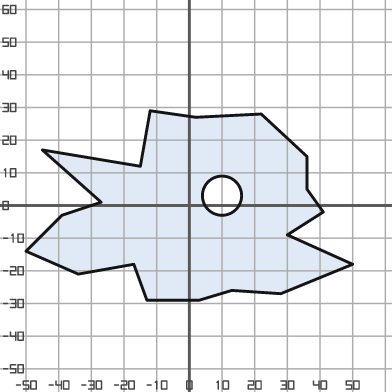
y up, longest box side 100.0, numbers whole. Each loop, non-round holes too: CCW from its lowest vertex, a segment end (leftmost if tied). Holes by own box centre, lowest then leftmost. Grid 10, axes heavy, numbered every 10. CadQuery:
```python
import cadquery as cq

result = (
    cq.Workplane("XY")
    .moveTo(-13.0, -29.0)
    .lineTo(3.0, -29.0)
    .lineTo(13.0, -26.0)
    .lineTo(28.0, -27.0)
    .lineTo(50.0, -18.0)
    .lineTo(30.0, -9.0)
    .lineTo(41.0, -2.0)
    .lineTo(36.0, 5.0)
    .lineTo(36.0, 15.0)
    .lineTo(22.0, 28.0)
    .lineTo(2.0, 27.0)
    .lineTo(-12.0, 29.0)
    .lineTo(-15.0, 12.0)
    .lineTo(-45.0, 17.0)
    .lineTo(-27.0, 1.0)
    .lineTo(-39.0, -3.0)
    .lineTo(-50.0, -14.0)
    .lineTo(-34.0, -21.0)
    .lineTo(-17.0, -18.0)
    .close()
    .moveTo(10.0, 3.0)
    .circle(6.0)
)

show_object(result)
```